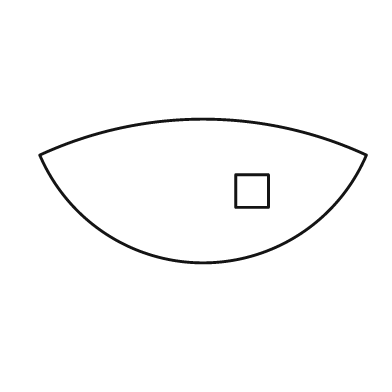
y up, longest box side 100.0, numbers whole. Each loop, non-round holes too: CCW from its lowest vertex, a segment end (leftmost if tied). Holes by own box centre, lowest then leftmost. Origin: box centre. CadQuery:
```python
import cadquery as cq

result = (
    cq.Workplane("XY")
    .moveTo(-50.0, 11.0)
    .threePointArc((0.0, -22.0), (50.0, 11.0))
    .threePointArc((0.0, 22.0), (-50.0, 11.0))
    .close()
    .moveTo(10.0, -5.0)
    .lineTo(20.0, -5.0)
    .lineTo(20.0, 5.0)
    .lineTo(10.0, 5.0)
    .close()
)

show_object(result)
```